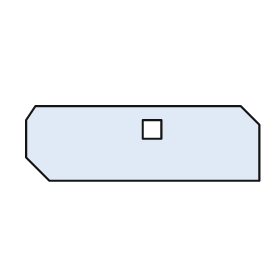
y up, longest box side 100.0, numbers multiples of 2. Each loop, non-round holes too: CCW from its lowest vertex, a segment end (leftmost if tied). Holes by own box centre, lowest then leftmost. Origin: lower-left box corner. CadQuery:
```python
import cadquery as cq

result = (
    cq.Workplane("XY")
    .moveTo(10.0, 0.0)
    .lineTo(100.0, 0.0)
    .lineTo(100.0, 24.0)
    .lineTo(92.0, 32.0)
    .lineTo(4.0, 32.0)
    .lineTo(0.0, 26.0)
    .lineTo(0.0, 10.0)
    .close()
    .moveTo(50.0, 18.0)
    .lineTo(58.0, 18.0)
    .lineTo(58.0, 26.0)
    .lineTo(50.0, 26.0)
    .close()
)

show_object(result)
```